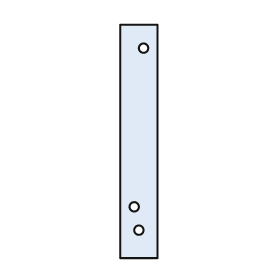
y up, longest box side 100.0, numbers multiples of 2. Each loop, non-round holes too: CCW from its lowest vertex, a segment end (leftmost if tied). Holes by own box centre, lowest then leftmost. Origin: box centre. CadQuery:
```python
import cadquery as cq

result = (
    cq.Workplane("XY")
    .moveTo(-8.0, -50.0)
    .lineTo(8.0, -50.0)
    .lineTo(8.0, 50.0)
    .lineTo(-8.0, 50.0)
    .close()
    .moveTo(0.0, -38.0)
    .circle(2.0)
    .moveTo(-2.0, -28.0)
    .circle(2.0)
    .moveTo(2.0, 40.0)
    .circle(2.0)
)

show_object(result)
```